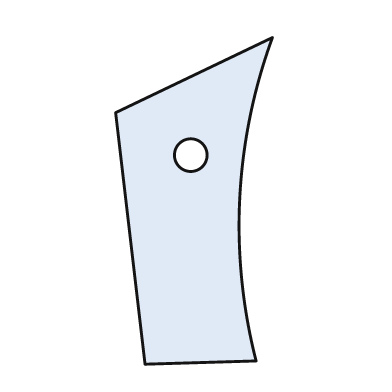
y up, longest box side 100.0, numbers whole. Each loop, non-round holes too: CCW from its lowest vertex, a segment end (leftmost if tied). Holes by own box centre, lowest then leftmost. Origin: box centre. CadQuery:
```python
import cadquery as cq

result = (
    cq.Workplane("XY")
    .moveTo(-15.0, -50.0)
    .lineTo(19.0, -49.0)
    .threePointArc((14.0, 1.0), (24.0, 50.0))
    .lineTo(-24.0, 27.0)
    .close()
    .moveTo(-1.0, 14.0)
    .circle(5.0)
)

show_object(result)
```